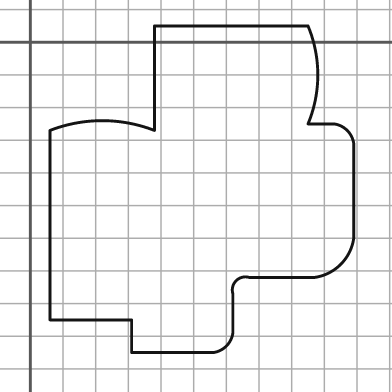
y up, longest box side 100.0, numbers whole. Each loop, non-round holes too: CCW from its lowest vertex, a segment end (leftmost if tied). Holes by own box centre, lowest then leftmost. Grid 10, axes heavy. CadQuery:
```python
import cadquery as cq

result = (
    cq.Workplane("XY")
    .moveTo(31.0, -95.0)
    .lineTo(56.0, -95.0)
    .threePointArc((60.0, -93.0), (62.0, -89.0))
    .lineTo(62.0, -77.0)
    .threePointArc((63.0, -73.0), (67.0, -72.0))
    .lineTo(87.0, -72.0)
    .threePointArc((95.0, -68.0), (99.0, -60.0))
    .lineTo(99.0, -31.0)
    .threePointArc((97.0, -27.0), (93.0, -25.0))
    .lineTo(85.0, -25.0)
    .threePointArc((88.0, -10.0), (85.0, 5.0))
    .lineTo(38.0, 5.0)
    .lineTo(38.0, -27.0)
    .threePointArc((22.0, -24.0), (6.0, -27.0))
    .lineTo(6.0, -85.0)
    .lineTo(31.0, -85.0)
    .close()
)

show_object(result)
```